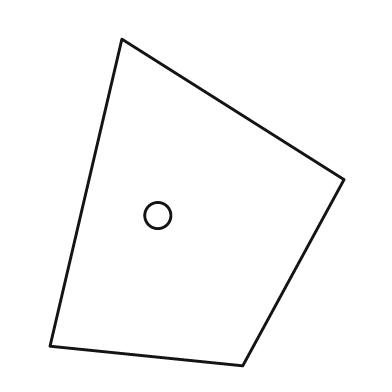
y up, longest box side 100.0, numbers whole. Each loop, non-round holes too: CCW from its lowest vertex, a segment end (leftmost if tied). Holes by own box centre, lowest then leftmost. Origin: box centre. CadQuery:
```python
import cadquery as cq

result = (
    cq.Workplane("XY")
    .moveTo(14.0, -50.0)
    .lineTo(45.0, 7.0)
    .lineTo(-23.0, 50.0)
    .lineTo(-45.0, -44.0)
    .close()
    .moveTo(-12.0, -4.0)
    .circle(4.0)
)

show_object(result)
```